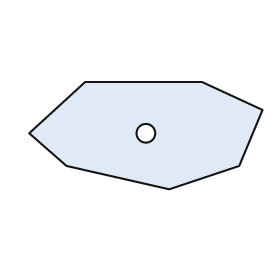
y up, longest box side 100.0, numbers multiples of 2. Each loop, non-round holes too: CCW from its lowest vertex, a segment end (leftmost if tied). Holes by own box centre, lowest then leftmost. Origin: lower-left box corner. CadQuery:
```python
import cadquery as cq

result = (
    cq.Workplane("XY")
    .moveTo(60.0, 0.0)
    .lineTo(90.0, 10.0)
    .lineTo(100.0, 34.0)
    .lineTo(74.0, 46.0)
    .lineTo(24.0, 46.0)
    .lineTo(0.0, 24.0)
    .lineTo(16.0, 10.0)
    .close()
    .moveTo(50.0, 24.0)
    .circle(4.0)
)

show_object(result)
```